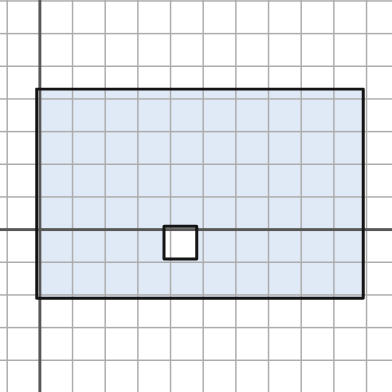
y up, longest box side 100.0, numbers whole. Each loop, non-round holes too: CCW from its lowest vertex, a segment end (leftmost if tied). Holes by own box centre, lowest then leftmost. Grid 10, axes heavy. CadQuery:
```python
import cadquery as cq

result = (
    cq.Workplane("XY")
    .moveTo(-1.0, -21.0)
    .lineTo(99.0, -21.0)
    .lineTo(99.0, 43.0)
    .lineTo(-1.0, 43.0)
    .close()
    .moveTo(38.0, -9.0)
    .lineTo(48.0, -9.0)
    .lineTo(48.0, 1.0)
    .lineTo(38.0, 1.0)
    .close()
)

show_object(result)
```